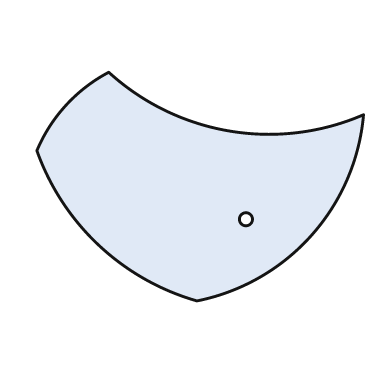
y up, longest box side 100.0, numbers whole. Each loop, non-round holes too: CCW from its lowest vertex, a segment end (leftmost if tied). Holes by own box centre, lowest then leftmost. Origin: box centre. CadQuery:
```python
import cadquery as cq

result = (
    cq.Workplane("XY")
    .moveTo(-1.0, -35.0)
    .threePointArc((34.0, -15.0), (50.0, 22.0))
    .threePointArc((9.0, 17.0), (-28.0, 35.0))
    .threePointArc((-41.0, 25.0), (-50.0, 11.0))
    .threePointArc((-31.0, -18.0), (-1.0, -35.0))
    .close()
    .moveTo(14.0, -10.0)
    .circle(2.0)
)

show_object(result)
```